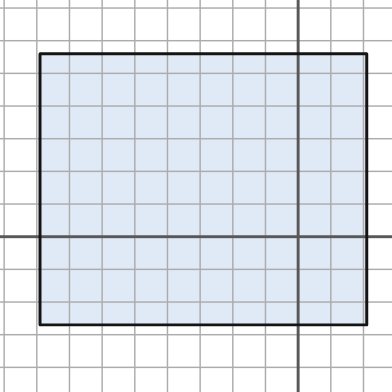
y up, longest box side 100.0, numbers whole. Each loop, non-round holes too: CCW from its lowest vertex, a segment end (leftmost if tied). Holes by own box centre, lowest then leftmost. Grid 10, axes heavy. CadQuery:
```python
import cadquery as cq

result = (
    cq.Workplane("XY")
    .moveTo(-79.0, -27.0)
    .lineTo(21.0, -27.0)
    .lineTo(21.0, 56.0)
    .lineTo(-79.0, 56.0)
    .close()
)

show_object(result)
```